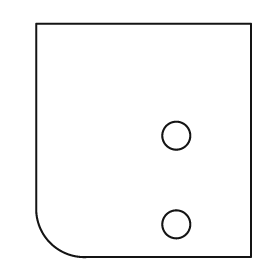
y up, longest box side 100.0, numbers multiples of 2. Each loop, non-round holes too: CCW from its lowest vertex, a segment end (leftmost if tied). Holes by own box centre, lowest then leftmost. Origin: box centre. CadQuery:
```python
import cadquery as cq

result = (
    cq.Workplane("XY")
    .moveTo(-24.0, -50.0)
    .lineTo(46.0, -50.0)
    .lineTo(46.0, 50.0)
    .lineTo(-46.0, 50.0)
    .lineTo(-46.0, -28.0)
    .threePointArc((-40.0, -44.0), (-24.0, -50.0))
    .close()
    .moveTo(14.0, -36.0)
    .circle(6.0)
    .moveTo(14.0, 2.0)
    .circle(6.0)
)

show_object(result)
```